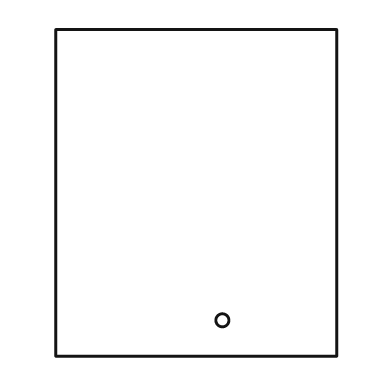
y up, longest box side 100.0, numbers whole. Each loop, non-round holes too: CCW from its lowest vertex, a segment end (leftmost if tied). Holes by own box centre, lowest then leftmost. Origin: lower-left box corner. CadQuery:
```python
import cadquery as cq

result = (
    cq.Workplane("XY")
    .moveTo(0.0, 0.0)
    .lineTo(86.0, 0.0)
    .lineTo(86.0, 100.0)
    .lineTo(0.0, 100.0)
    .close()
    .moveTo(51.0, 11.0)
    .circle(2.0)
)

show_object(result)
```